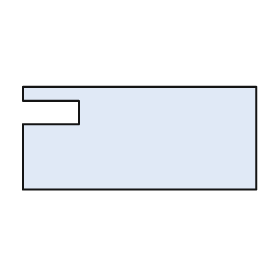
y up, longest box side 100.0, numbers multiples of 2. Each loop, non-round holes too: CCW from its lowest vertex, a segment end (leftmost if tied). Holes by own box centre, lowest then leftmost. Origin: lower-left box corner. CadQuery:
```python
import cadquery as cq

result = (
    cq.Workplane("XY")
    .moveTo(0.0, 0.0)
    .lineTo(100.0, 0.0)
    .lineTo(100.0, 44.0)
    .lineTo(0.0, 44.0)
    .lineTo(0.0, 38.0)
    .lineTo(24.0, 38.0)
    .lineTo(24.0, 28.0)
    .lineTo(0.0, 28.0)
    .close()
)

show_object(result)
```